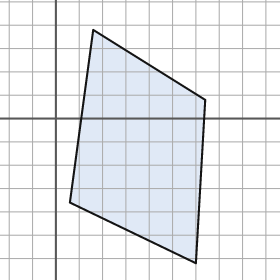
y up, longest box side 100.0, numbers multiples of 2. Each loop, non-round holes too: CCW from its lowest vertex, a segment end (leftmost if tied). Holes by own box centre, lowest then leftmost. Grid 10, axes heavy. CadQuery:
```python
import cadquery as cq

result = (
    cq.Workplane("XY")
    .moveTo(60.0, -62.0)
    .lineTo(64.0, 8.0)
    .lineTo(16.0, 38.0)
    .lineTo(6.0, -36.0)
    .close()
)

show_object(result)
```